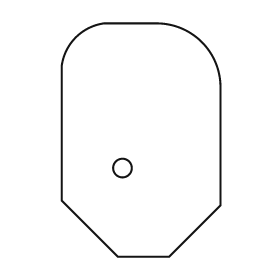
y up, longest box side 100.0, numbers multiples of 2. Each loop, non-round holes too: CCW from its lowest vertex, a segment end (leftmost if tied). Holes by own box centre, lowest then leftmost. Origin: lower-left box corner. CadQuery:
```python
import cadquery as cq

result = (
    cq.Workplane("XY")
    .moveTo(24.0, 0.0)
    .lineTo(46.0, 0.0)
    .lineTo(68.0, 22.0)
    .lineTo(68.0, 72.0)
    .threePointArc((60.0, 92.0), (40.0, 100.0))
    .lineTo(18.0, 100.0)
    .threePointArc((6.0, 94.0), (0.0, 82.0))
    .lineTo(0.0, 24.0)
    .close()
    .moveTo(26.0, 38.0)
    .circle(4.0)
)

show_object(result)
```